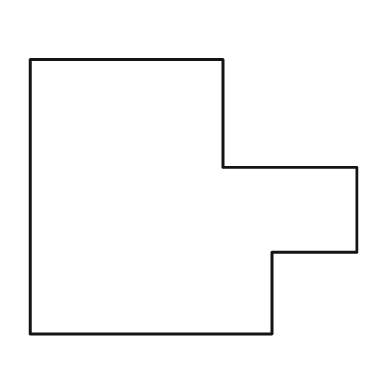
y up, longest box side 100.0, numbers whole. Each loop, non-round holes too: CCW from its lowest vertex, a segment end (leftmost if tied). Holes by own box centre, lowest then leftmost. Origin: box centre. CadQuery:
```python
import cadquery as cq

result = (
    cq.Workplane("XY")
    .moveTo(-50.0, -42.0)
    .lineTo(24.0, -42.0)
    .lineTo(24.0, -17.0)
    .lineTo(50.0, -17.0)
    .lineTo(50.0, 9.0)
    .lineTo(9.0, 9.0)
    .lineTo(9.0, 42.0)
    .lineTo(-50.0, 42.0)
    .close()
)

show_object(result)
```